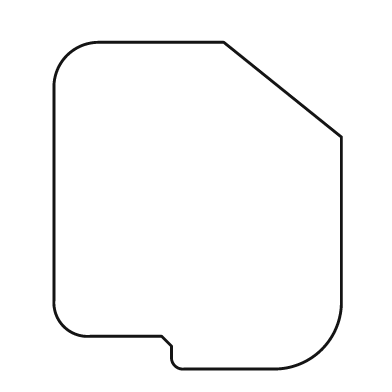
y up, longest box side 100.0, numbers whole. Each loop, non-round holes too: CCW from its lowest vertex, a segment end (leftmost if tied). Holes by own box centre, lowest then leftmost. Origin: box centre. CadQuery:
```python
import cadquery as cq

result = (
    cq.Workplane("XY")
    .moveTo(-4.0, -50.0)
    .lineTo(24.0, -50.0)
    .threePointArc((38.0, -44.0), (44.0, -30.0))
    .lineTo(44.0, 21.0)
    .lineTo(8.0, 50.0)
    .lineTo(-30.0, 50.0)
    .threePointArc((-40.0, 46.0), (-44.0, 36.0))
    .lineTo(-44.0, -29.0)
    .threePointArc((-41.0, -37.0), (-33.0, -40.0))
    .lineTo(-11.0, -40.0)
    .lineTo(-8.0, -43.0)
    .lineTo(-8.0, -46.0)
    .threePointArc((-7.0, -49.0), (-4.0, -50.0))
    .close()
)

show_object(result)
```